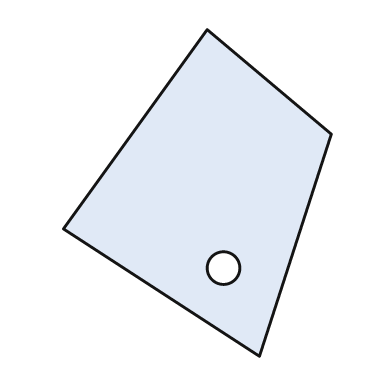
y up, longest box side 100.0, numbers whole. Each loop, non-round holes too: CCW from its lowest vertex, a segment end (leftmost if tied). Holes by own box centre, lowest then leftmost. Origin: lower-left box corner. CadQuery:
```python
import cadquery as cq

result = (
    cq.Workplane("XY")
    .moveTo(60.0, 0.0)
    .lineTo(82.0, 68.0)
    .lineTo(44.0, 100.0)
    .lineTo(0.0, 39.0)
    .close()
    .moveTo(49.0, 27.0)
    .circle(5.0)
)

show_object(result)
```